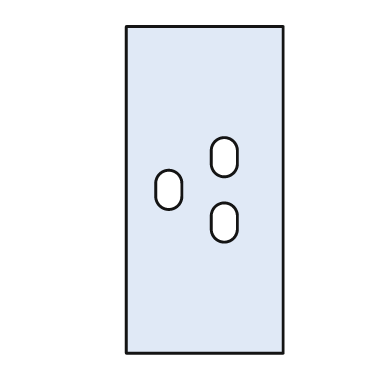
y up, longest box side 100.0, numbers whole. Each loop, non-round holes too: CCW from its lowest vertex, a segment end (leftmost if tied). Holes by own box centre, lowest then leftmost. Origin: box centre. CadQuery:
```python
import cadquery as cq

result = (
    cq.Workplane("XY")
    .moveTo(-24.0, -50.0)
    .lineTo(24.0, -50.0)
    .lineTo(24.0, 50.0)
    .lineTo(-24.0, 50.0)
    .close()
    .moveTo(2.0, -12.0)
    .threePointArc((6.0, -16.0), (10.0, -12.0))
    .lineTo(10.0, -8.0)
    .threePointArc((6.0, -4.0), (2.0, -8.0))
    .close()
    .moveTo(-15.0, -2.0)
    .threePointArc((-11.0, -6.0), (-7.0, -2.0))
    .lineTo(-7.0, 2.0)
    .threePointArc((-11.0, 6.0), (-15.0, 2.0))
    .close()
    .moveTo(2.0, 8.0)
    .threePointArc((6.0, 4.0), (10.0, 8.0))
    .lineTo(10.0, 12.0)
    .threePointArc((6.0, 16.0), (2.0, 12.0))
    .close()
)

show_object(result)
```